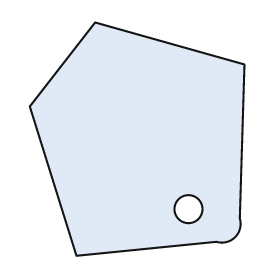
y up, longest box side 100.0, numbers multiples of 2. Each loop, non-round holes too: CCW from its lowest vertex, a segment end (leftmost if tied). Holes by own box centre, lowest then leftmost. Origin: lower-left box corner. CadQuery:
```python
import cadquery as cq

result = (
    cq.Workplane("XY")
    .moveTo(20.0, 0.0)
    .lineTo(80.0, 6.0)
    .threePointArc((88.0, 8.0), (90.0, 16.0))
    .lineTo(92.0, 82.0)
    .lineTo(28.0, 100.0)
    .lineTo(0.0, 64.0)
    .close()
    .moveTo(68.0, 20.0)
    .circle(6.0)
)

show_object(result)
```